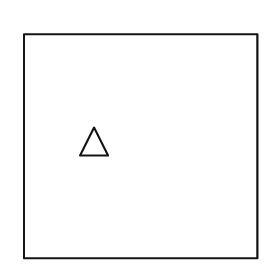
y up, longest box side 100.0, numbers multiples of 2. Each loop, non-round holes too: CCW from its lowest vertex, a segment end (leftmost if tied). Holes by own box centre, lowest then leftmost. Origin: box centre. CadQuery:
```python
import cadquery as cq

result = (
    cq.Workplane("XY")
    .moveTo(-50.0, -48.0)
    .lineTo(50.0, -48.0)
    .lineTo(50.0, 48.0)
    .lineTo(-50.0, 48.0)
    .close()
    .moveTo(-26.0, -4.0)
    .lineTo(-14.0, -4.0)
    .lineTo(-20.0, 8.0)
    .close()
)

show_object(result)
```